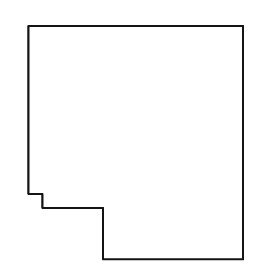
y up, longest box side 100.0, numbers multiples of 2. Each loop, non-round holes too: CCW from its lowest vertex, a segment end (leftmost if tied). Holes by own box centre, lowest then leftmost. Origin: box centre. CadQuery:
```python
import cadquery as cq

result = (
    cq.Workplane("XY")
    .moveTo(-14.0, -50.0)
    .lineTo(46.0, -50.0)
    .lineTo(46.0, 50.0)
    .lineTo(-46.0, 50.0)
    .lineTo(-46.0, -22.0)
    .lineTo(-40.0, -22.0)
    .lineTo(-40.0, -28.0)
    .lineTo(-14.0, -28.0)
    .close()
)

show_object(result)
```